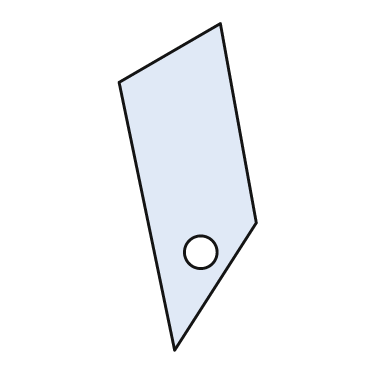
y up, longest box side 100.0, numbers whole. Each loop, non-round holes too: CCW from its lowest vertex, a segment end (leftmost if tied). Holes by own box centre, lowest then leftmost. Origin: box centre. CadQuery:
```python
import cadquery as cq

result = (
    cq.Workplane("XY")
    .moveTo(-4.0, -50.0)
    .lineTo(21.0, -11.0)
    .lineTo(10.0, 50.0)
    .lineTo(-21.0, 32.0)
    .close()
    .moveTo(4.0, -20.0)
    .circle(5.0)
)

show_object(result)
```